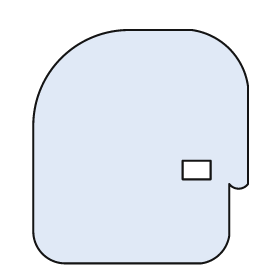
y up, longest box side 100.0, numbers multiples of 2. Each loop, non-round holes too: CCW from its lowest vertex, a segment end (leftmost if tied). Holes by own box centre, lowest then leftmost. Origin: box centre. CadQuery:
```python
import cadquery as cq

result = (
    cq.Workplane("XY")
    .moveTo(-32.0, -50.0)
    .lineTo(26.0, -50.0)
    .threePointArc((34.0, -46.0), (38.0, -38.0))
    .lineTo(38.0, -16.0)
    .threePointArc((42.0, -18.0), (46.0, -16.0))
    .lineTo(46.0, 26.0)
    .threePointArc((38.0, 42.0), (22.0, 50.0))
    .lineTo(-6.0, 50.0)
    .threePointArc((-34.0, 38.0), (-46.0, 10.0))
    .lineTo(-46.0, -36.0)
    .threePointArc((-42.0, -46.0), (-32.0, -50.0))
    .close()
    .moveTo(18.0, -14.0)
    .lineTo(30.0, -14.0)
    .lineTo(30.0, -6.0)
    .lineTo(18.0, -6.0)
    .close()
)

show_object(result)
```